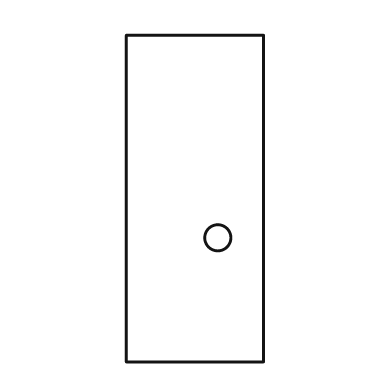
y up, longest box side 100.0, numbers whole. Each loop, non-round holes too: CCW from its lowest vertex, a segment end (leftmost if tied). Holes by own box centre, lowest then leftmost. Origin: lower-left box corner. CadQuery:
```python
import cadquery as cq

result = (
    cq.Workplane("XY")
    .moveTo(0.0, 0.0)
    .lineTo(42.0, 0.0)
    .lineTo(42.0, 100.0)
    .lineTo(0.0, 100.0)
    .close()
    .moveTo(28.0, 38.0)
    .circle(4.0)
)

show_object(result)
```